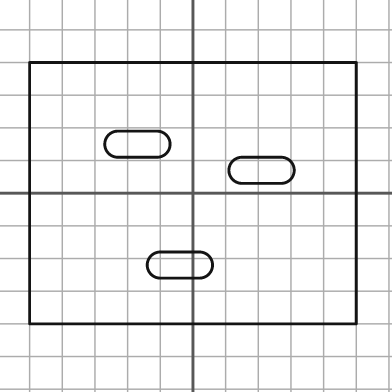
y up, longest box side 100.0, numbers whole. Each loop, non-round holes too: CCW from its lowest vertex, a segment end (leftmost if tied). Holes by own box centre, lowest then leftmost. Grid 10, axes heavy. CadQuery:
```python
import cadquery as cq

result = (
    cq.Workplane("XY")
    .moveTo(-50.0, -40.0)
    .lineTo(50.0, -40.0)
    .lineTo(50.0, 40.0)
    .lineTo(-50.0, 40.0)
    .close()
    .moveTo(-10.0, -26.0)
    .lineTo(2.0, -26.0)
    .threePointArc((6.0, -22.0), (2.0, -18.0))
    .lineTo(-10.0, -18.0)
    .threePointArc((-14.0, -22.0), (-10.0, -26.0))
    .close()
    .moveTo(15.0, 3.0)
    .lineTo(27.0, 3.0)
    .threePointArc((31.0, 7.0), (27.0, 11.0))
    .lineTo(15.0, 11.0)
    .threePointArc((11.0, 7.0), (15.0, 3.0))
    .close()
    .moveTo(-23.0, 11.0)
    .lineTo(-11.0, 11.0)
    .threePointArc((-7.0, 15.0), (-11.0, 19.0))
    .lineTo(-23.0, 19.0)
    .threePointArc((-27.0, 15.0), (-23.0, 11.0))
    .close()
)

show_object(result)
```